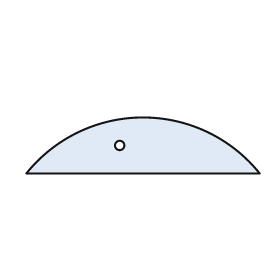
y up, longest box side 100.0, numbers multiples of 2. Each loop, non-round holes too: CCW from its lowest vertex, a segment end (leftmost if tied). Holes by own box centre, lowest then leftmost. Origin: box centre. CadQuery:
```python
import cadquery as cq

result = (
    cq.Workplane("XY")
    .moveTo(-50.0, -12.0)
    .lineTo(50.0, -12.0)
    .threePointArc((0.0, 12.0), (-50.0, -12.0))
    .close()
    .moveTo(-10.0, 0.0)
    .circle(2.0)
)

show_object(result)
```